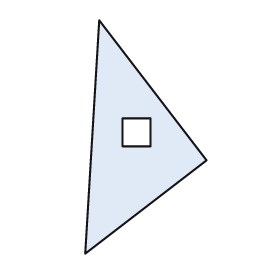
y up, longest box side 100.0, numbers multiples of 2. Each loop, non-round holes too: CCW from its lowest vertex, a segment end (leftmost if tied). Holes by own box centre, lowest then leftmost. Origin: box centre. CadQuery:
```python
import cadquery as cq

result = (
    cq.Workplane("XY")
    .moveTo(-26.0, -50.0)
    .lineTo(26.0, -10.0)
    .lineTo(-20.0, 50.0)
    .close()
    .moveTo(-10.0, -4.0)
    .lineTo(2.0, -4.0)
    .lineTo(2.0, 8.0)
    .lineTo(-10.0, 8.0)
    .close()
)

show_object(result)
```